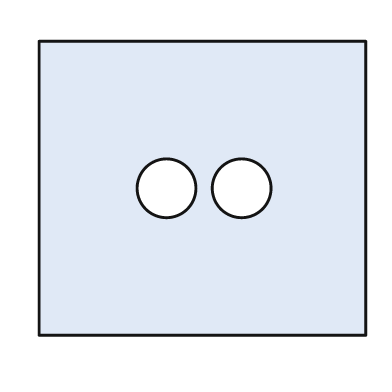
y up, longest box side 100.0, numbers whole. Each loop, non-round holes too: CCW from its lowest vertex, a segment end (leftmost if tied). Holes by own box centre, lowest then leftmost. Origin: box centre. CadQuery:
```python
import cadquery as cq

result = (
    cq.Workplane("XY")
    .moveTo(-50.0, -45.0)
    .lineTo(50.0, -45.0)
    .lineTo(50.0, 45.0)
    .lineTo(-50.0, 45.0)
    .close()
    .moveTo(-11.0, 0.0)
    .circle(9.0)
    .moveTo(12.0, 0.0)
    .circle(9.0)
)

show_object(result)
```